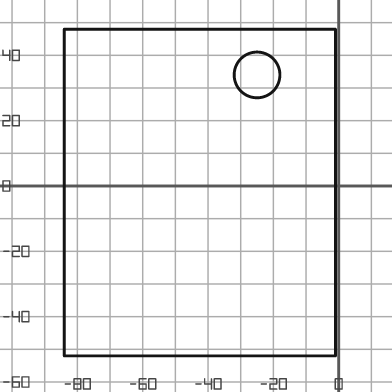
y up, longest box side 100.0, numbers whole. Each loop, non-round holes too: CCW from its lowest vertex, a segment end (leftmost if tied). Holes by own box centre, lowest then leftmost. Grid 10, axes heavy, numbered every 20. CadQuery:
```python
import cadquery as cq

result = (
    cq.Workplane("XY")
    .moveTo(-84.0, -52.0)
    .lineTo(-1.0, -52.0)
    .lineTo(-1.0, 48.0)
    .lineTo(-84.0, 48.0)
    .close()
    .moveTo(-25.0, 34.0)
    .circle(7.0)
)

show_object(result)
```